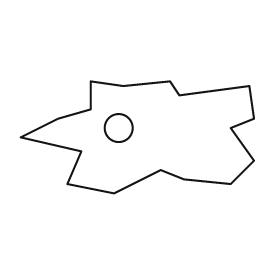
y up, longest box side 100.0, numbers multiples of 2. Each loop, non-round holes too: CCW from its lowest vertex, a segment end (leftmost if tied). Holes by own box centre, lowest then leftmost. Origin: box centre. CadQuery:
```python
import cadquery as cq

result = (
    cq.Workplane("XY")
    .moveTo(-10.0, -24.0)
    .lineTo(10.0, -14.0)
    .lineTo(20.0, -18.0)
    .lineTo(40.0, -20.0)
    .lineTo(50.0, -10.0)
    .lineTo(40.0, 4.0)
    .lineTo(50.0, 8.0)
    .lineTo(48.0, 22.0)
    .lineTo(18.0, 18.0)
    .lineTo(14.0, 24.0)
    .lineTo(-6.0, 22.0)
    .lineTo(-20.0, 24.0)
    .lineTo(-20.0, 12.0)
    .lineTo(-34.0, 8.0)
    .lineTo(-50.0, 0.0)
    .lineTo(-24.0, -6.0)
    .lineTo(-30.0, -20.0)
    .close()
    .moveTo(-8.0, 4.0)
    .circle(6.0)
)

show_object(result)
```